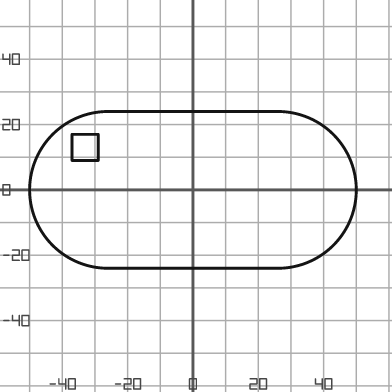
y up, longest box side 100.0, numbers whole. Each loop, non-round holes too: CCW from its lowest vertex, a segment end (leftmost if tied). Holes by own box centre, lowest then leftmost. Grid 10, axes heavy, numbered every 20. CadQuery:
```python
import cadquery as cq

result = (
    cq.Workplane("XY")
    .moveTo(-26.0, -24.0)
    .lineTo(26.0, -24.0)
    .threePointArc((50.0, 0.0), (26.0, 24.0))
    .lineTo(-26.0, 24.0)
    .threePointArc((-50.0, 0.0), (-26.0, -24.0))
    .close()
    .moveTo(-37.0, 9.0)
    .lineTo(-29.0, 9.0)
    .lineTo(-29.0, 17.0)
    .lineTo(-37.0, 17.0)
    .close()
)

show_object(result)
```